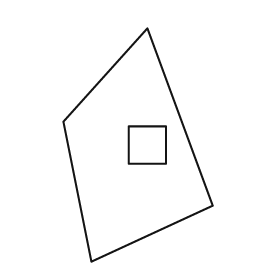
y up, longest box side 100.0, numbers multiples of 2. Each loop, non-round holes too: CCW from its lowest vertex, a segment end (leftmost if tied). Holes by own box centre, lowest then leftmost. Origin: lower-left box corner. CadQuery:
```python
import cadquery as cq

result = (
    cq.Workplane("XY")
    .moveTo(12.0, 0.0)
    .lineTo(64.0, 24.0)
    .lineTo(36.0, 100.0)
    .lineTo(0.0, 60.0)
    .close()
    .moveTo(28.0, 42.0)
    .lineTo(44.0, 42.0)
    .lineTo(44.0, 58.0)
    .lineTo(28.0, 58.0)
    .close()
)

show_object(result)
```